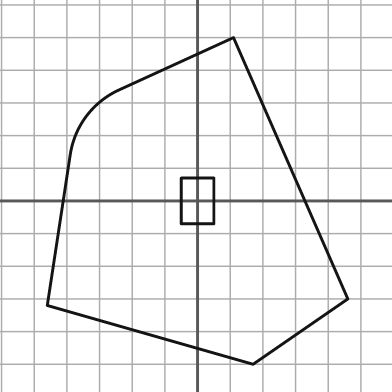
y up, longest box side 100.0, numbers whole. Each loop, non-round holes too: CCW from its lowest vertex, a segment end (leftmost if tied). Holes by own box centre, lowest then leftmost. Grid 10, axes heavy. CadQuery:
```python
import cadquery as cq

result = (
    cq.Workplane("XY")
    .moveTo(17.0, -50.0)
    .lineTo(46.0, -30.0)
    .lineTo(11.0, 50.0)
    .lineTo(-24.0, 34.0)
    .threePointArc((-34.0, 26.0), (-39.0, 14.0))
    .lineTo(-46.0, -32.0)
    .close()
    .moveTo(-5.0, -7.0)
    .lineTo(5.0, -7.0)
    .lineTo(5.0, 7.0)
    .lineTo(-5.0, 7.0)
    .close()
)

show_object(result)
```